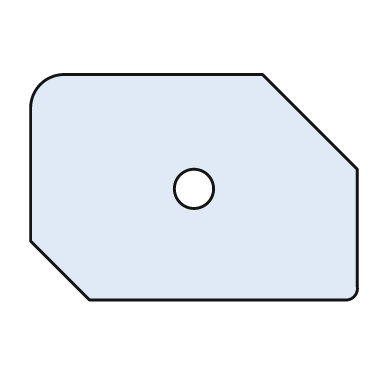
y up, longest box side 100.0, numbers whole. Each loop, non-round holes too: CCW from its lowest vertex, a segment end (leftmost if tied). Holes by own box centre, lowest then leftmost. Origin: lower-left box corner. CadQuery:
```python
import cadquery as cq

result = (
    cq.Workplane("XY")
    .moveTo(18.0, 0.0)
    .lineTo(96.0, 0.0)
    .threePointArc((99.0, 1.0), (100.0, 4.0))
    .lineTo(100.0, 40.0)
    .lineTo(71.0, 69.0)
    .lineTo(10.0, 69.0)
    .threePointArc((3.0, 66.0), (0.0, 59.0))
    .lineTo(0.0, 18.0)
    .close()
    .moveTo(50.0, 34.0)
    .circle(6.0)
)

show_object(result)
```